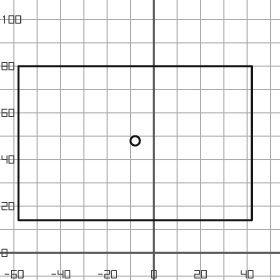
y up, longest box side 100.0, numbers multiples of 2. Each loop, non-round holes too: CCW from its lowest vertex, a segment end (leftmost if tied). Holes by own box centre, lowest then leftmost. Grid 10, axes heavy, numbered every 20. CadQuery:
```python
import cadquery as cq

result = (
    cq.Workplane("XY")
    .moveTo(-58.0, 14.0)
    .lineTo(42.0, 14.0)
    .lineTo(42.0, 80.0)
    .lineTo(-58.0, 80.0)
    .close()
    .moveTo(-8.0, 48.0)
    .circle(2.0)
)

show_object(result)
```